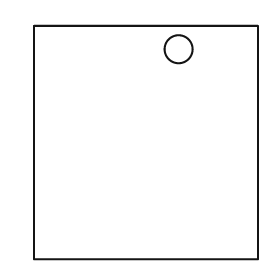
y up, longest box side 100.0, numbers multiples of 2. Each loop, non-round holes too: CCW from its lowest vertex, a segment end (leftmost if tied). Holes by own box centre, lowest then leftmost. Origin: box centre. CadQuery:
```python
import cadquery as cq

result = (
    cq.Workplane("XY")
    .moveTo(-48.0, -50.0)
    .lineTo(48.0, -50.0)
    .lineTo(48.0, 50.0)
    .lineTo(-48.0, 50.0)
    .close()
    .moveTo(14.0, 40.0)
    .circle(6.0)
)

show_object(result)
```